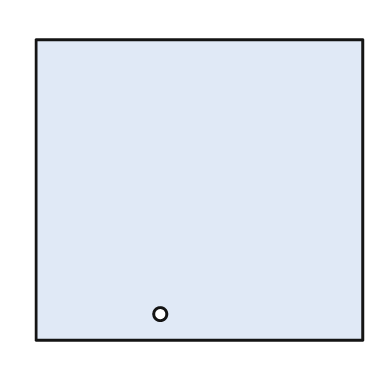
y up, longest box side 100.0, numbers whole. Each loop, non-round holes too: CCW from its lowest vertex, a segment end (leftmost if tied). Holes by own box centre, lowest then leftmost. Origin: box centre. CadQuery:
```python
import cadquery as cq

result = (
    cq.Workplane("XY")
    .moveTo(-50.0, -46.0)
    .lineTo(50.0, -46.0)
    .lineTo(50.0, 46.0)
    .lineTo(-50.0, 46.0)
    .close()
    .moveTo(-12.0, -38.0)
    .circle(2.0)
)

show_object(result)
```